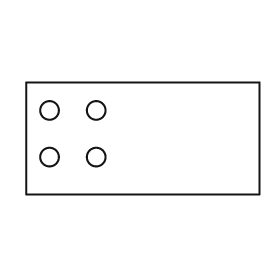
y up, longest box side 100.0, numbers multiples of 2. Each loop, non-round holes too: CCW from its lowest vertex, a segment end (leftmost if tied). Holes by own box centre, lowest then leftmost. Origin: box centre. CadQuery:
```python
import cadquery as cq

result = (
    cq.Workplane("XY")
    .moveTo(-50.0, -24.0)
    .lineTo(50.0, -24.0)
    .lineTo(50.0, 24.0)
    .lineTo(-50.0, 24.0)
    .close()
    .moveTo(-40.0, -8.0)
    .circle(4.0)
    .moveTo(-20.0, -8.0)
    .circle(4.0)
    .moveTo(-40.0, 12.0)
    .circle(4.0)
    .moveTo(-20.0, 12.0)
    .circle(4.0)
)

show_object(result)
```